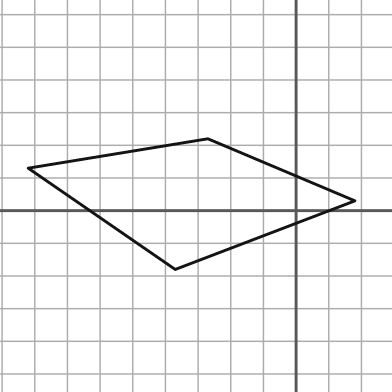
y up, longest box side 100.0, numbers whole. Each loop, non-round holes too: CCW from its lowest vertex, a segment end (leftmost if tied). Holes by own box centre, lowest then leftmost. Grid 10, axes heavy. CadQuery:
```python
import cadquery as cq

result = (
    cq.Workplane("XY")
    .moveTo(-37.0, -18.0)
    .lineTo(18.0, 3.0)
    .lineTo(-27.0, 22.0)
    .lineTo(-82.0, 13.0)
    .close()
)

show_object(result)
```